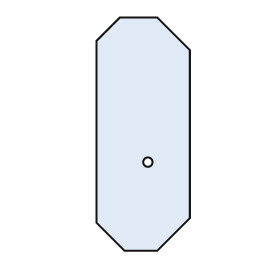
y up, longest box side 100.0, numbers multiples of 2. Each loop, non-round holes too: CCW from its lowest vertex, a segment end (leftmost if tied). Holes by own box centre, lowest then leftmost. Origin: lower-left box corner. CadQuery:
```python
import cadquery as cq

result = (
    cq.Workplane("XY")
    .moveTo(12.0, 0.0)
    .lineTo(26.0, 0.0)
    .lineTo(40.0, 14.0)
    .lineTo(40.0, 86.0)
    .lineTo(26.0, 100.0)
    .lineTo(10.0, 100.0)
    .lineTo(0.0, 90.0)
    .lineTo(0.0, 12.0)
    .close()
    .moveTo(22.0, 38.0)
    .circle(2.0)
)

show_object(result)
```